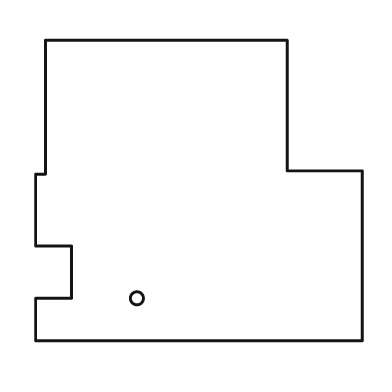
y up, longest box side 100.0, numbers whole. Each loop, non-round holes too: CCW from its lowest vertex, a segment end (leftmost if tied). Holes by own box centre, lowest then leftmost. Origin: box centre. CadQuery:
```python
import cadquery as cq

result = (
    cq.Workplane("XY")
    .moveTo(-50.0, -46.0)
    .lineTo(50.0, -46.0)
    .lineTo(50.0, 6.0)
    .lineTo(27.0, 6.0)
    .lineTo(27.0, 46.0)
    .lineTo(-47.0, 46.0)
    .lineTo(-47.0, 5.0)
    .lineTo(-50.0, 5.0)
    .lineTo(-50.0, -17.0)
    .lineTo(-39.0, -17.0)
    .lineTo(-39.0, -33.0)
    .lineTo(-50.0, -33.0)
    .close()
    .moveTo(-19.0, -33.0)
    .circle(2.0)
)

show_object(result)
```